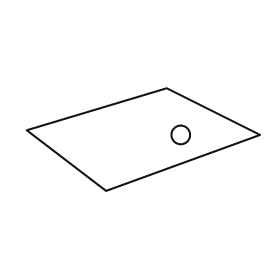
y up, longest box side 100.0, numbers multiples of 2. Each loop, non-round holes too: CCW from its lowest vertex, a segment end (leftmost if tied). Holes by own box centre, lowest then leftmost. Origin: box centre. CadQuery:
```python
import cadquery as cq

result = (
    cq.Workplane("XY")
    .moveTo(-16.0, -22.0)
    .lineTo(50.0, 2.0)
    .lineTo(10.0, 22.0)
    .lineTo(-50.0, 4.0)
    .close()
    .moveTo(16.0, 2.0)
    .circle(4.0)
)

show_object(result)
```